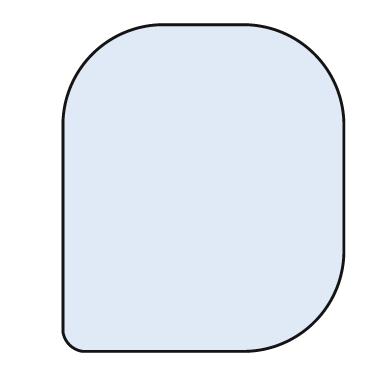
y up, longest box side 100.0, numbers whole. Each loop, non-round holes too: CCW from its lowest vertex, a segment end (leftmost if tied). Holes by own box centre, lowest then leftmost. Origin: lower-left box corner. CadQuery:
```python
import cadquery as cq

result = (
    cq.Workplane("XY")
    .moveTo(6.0, 0.0)
    .lineTo(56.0, 0.0)
    .threePointArc((77.0, 9.0), (86.0, 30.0))
    .lineTo(86.0, 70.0)
    .threePointArc((77.0, 91.0), (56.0, 100.0))
    .lineTo(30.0, 100.0)
    .threePointArc((9.0, 91.0), (0.0, 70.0))
    .lineTo(0.0, 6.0)
    .threePointArc((2.0, 2.0), (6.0, 0.0))
    .close()
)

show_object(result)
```